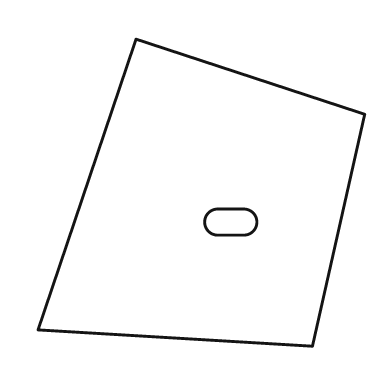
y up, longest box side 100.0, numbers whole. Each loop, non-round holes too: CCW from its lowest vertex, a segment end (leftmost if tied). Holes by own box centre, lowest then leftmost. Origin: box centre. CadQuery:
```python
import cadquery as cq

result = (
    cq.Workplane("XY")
    .moveTo(34.0, -47.0)
    .lineTo(50.0, 24.0)
    .lineTo(-20.0, 47.0)
    .lineTo(-50.0, -42.0)
    .close()
    .moveTo(5.0, -13.0)
    .lineTo(13.0, -13.0)
    .threePointArc((17.0, -9.0), (13.0, -5.0))
    .lineTo(5.0, -5.0)
    .threePointArc((1.0, -9.0), (5.0, -13.0))
    .close()
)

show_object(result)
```